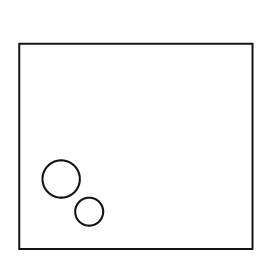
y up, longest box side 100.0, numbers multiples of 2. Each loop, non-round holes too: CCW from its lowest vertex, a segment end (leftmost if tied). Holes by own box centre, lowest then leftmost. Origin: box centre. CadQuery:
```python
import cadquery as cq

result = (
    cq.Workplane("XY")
    .moveTo(-50.0, -44.0)
    .lineTo(50.0, -44.0)
    .lineTo(50.0, 44.0)
    .lineTo(-50.0, 44.0)
    .close()
    .moveTo(-20.0, -28.0)
    .circle(6.0)
    .moveTo(-32.0, -14.0)
    .circle(8.0)
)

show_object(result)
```